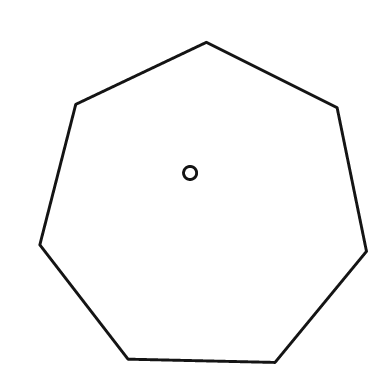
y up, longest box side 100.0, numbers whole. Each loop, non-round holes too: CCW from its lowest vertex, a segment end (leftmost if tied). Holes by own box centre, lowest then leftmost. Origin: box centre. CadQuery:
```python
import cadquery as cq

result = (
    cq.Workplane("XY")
    .moveTo(22.0, -49.0)
    .lineTo(50.0, -15.0)
    .lineTo(41.0, 29.0)
    .lineTo(1.0, 49.0)
    .lineTo(-39.0, 30.0)
    .lineTo(-50.0, -13.0)
    .lineTo(-23.0, -48.0)
    .close()
    .moveTo(-4.0, 9.0)
    .circle(2.0)
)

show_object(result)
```